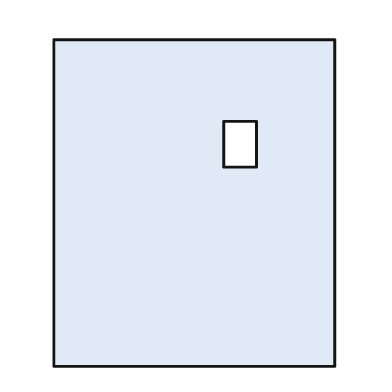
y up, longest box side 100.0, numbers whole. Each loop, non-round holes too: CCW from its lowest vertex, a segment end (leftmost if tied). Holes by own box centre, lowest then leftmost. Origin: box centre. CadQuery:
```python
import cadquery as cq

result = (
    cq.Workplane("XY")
    .moveTo(-43.0, -50.0)
    .lineTo(43.0, -50.0)
    .lineTo(43.0, 50.0)
    .lineTo(-43.0, 50.0)
    .close()
    .moveTo(9.0, 11.0)
    .lineTo(19.0, 11.0)
    .lineTo(19.0, 25.0)
    .lineTo(9.0, 25.0)
    .close()
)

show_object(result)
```